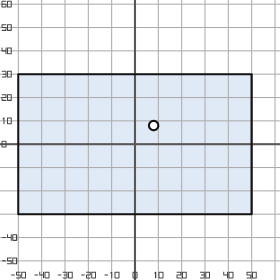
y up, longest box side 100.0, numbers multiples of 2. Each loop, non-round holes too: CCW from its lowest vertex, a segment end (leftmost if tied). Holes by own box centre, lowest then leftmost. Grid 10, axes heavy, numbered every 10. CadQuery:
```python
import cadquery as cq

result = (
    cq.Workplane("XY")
    .moveTo(-50.0, -30.0)
    .lineTo(50.0, -30.0)
    .lineTo(50.0, 30.0)
    .lineTo(-50.0, 30.0)
    .close()
    .moveTo(8.0, 8.0)
    .circle(2.0)
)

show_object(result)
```